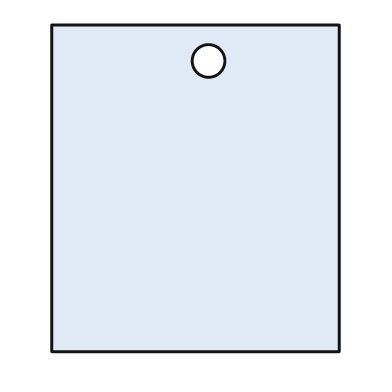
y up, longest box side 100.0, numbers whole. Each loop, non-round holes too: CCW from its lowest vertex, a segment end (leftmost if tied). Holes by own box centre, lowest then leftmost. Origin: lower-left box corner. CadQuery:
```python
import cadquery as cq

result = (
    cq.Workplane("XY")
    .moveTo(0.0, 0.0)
    .lineTo(88.0, 0.0)
    .lineTo(88.0, 100.0)
    .lineTo(0.0, 100.0)
    .close()
    .moveTo(48.0, 89.0)
    .circle(5.0)
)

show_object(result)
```